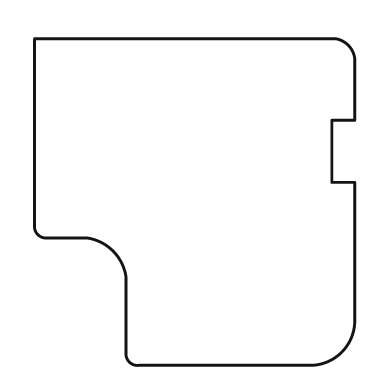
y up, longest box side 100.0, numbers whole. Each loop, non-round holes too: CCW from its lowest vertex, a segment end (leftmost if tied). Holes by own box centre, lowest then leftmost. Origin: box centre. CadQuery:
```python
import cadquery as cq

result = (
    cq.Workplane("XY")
    .moveTo(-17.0, -50.0)
    .lineTo(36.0, -50.0)
    .threePointArc((45.0, -46.0), (49.0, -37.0))
    .lineTo(49.0, 6.0)
    .lineTo(42.0, 6.0)
    .lineTo(42.0, 25.0)
    .lineTo(49.0, 25.0)
    .lineTo(49.0, 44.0)
    .threePointArc((47.0, 48.0), (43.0, 50.0))
    .lineTo(-49.0, 50.0)
    .lineTo(-49.0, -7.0)
    .threePointArc((-48.0, -10.0), (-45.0, -11.0))
    .lineTo(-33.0, -11.0)
    .threePointArc((-25.0, -15.0), (-21.0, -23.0))
    .lineTo(-21.0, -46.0)
    .threePointArc((-20.0, -49.0), (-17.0, -50.0))
    .close()
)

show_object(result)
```